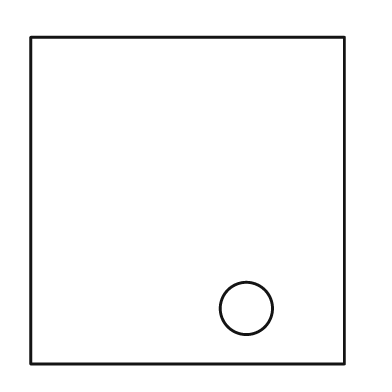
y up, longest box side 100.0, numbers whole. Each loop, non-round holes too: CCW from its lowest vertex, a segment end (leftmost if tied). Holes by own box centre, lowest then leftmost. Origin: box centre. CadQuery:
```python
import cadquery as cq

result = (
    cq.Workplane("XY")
    .moveTo(-48.0, -50.0)
    .lineTo(48.0, -50.0)
    .lineTo(48.0, 50.0)
    .lineTo(-48.0, 50.0)
    .close()
    .moveTo(18.0, -33.0)
    .circle(8.0)
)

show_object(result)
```